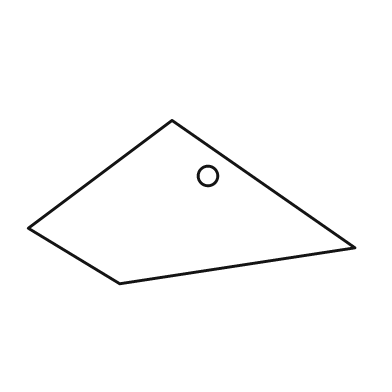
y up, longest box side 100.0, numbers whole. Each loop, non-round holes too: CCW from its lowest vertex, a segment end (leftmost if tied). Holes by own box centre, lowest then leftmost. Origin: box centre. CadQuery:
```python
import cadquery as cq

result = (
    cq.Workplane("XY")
    .moveTo(-22.0, -25.0)
    .lineTo(50.0, -14.0)
    .lineTo(-6.0, 25.0)
    .lineTo(-50.0, -8.0)
    .close()
    .moveTo(5.0, 8.0)
    .circle(3.0)
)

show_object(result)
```